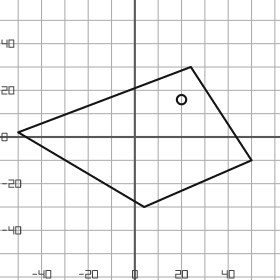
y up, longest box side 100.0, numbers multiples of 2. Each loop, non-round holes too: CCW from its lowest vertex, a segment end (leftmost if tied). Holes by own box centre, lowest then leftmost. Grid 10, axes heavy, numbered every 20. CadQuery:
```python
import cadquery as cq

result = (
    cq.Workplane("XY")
    .moveTo(4.0, -30.0)
    .lineTo(50.0, -10.0)
    .lineTo(24.0, 30.0)
    .lineTo(-50.0, 2.0)
    .close()
    .moveTo(20.0, 16.0)
    .circle(2.0)
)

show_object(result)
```